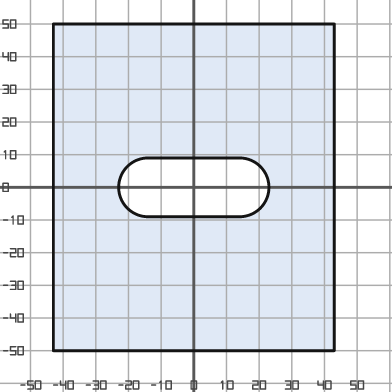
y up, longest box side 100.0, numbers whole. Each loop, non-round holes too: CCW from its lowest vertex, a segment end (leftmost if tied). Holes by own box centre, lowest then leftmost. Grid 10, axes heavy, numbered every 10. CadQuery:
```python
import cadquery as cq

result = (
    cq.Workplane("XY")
    .moveTo(-43.0, -50.0)
    .lineTo(43.0, -50.0)
    .lineTo(43.0, 50.0)
    .lineTo(-43.0, 50.0)
    .close()
    .moveTo(-14.0, -9.0)
    .lineTo(14.0, -9.0)
    .threePointArc((23.0, 0.0), (14.0, 9.0))
    .lineTo(-14.0, 9.0)
    .threePointArc((-23.0, 0.0), (-14.0, -9.0))
    .close()
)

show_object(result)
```